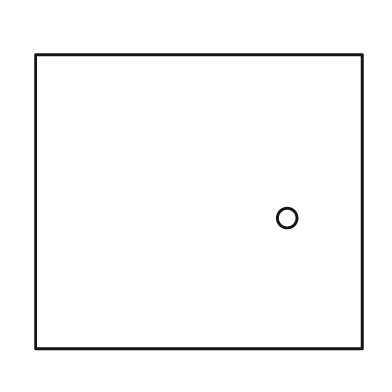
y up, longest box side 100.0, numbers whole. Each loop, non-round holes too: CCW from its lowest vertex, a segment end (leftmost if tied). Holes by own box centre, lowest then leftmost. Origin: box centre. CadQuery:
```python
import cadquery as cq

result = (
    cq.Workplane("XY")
    .moveTo(-50.0, -45.0)
    .lineTo(50.0, -45.0)
    .lineTo(50.0, 45.0)
    .lineTo(-50.0, 45.0)
    .close()
    .moveTo(27.0, -5.0)
    .circle(3.0)
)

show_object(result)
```